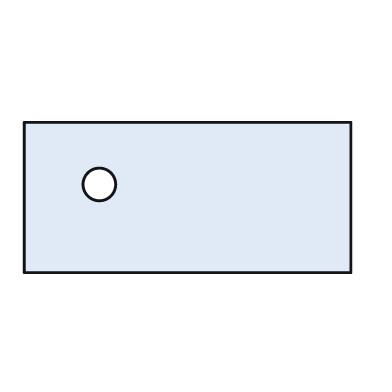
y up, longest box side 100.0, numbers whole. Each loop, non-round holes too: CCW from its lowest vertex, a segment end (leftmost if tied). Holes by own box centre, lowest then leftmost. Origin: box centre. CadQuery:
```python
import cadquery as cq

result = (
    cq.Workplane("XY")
    .moveTo(-50.0, -23.0)
    .lineTo(50.0, -23.0)
    .lineTo(50.0, 23.0)
    .lineTo(-50.0, 23.0)
    .close()
    .moveTo(-27.0, 4.0)
    .circle(5.0)
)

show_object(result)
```